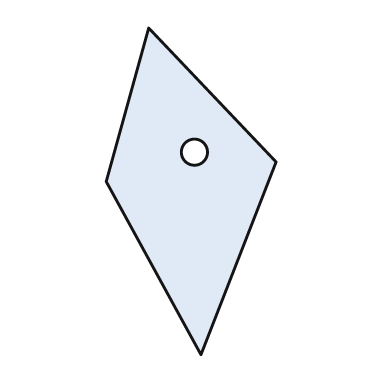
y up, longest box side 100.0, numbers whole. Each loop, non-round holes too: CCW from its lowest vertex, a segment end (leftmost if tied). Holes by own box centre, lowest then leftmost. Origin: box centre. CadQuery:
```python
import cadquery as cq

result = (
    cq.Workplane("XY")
    .moveTo(3.0, -50.0)
    .lineTo(26.0, 9.0)
    .lineTo(-13.0, 50.0)
    .lineTo(-26.0, 3.0)
    .close()
    .moveTo(1.0, 12.0)
    .circle(4.0)
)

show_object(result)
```